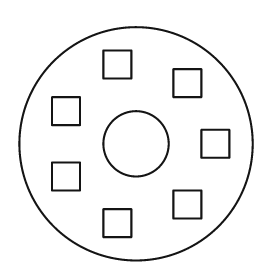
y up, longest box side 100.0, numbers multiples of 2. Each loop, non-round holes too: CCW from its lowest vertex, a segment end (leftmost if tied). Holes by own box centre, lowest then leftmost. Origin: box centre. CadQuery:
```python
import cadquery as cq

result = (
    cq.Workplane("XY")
    .moveTo(0.0, 0.0)
    .circle(50.0)
    .moveTo(-14.0, -40.0)
    .lineTo(-2.0, -40.0)
    .lineTo(-2.0, -28.0)
    .lineTo(-14.0, -28.0)
    .close()
    .moveTo(16.0, -32.0)
    .lineTo(28.0, -32.0)
    .lineTo(28.0, -20.0)
    .lineTo(16.0, -20.0)
    .close()
    .moveTo(-36.0, -20.0)
    .lineTo(-24.0, -20.0)
    .lineTo(-24.0, -8.0)
    .lineTo(-36.0, -8.0)
    .close()
    .moveTo(0.0, 0.0)
    .circle(14.0)
    .moveTo(28.0, -6.0)
    .lineTo(40.0, -6.0)
    .lineTo(40.0, 6.0)
    .lineTo(28.0, 6.0)
    .close()
    .moveTo(-36.0, 8.0)
    .lineTo(-24.0, 8.0)
    .lineTo(-24.0, 20.0)
    .lineTo(-36.0, 20.0)
    .close()
    .moveTo(16.0, 20.0)
    .lineTo(28.0, 20.0)
    .lineTo(28.0, 32.0)
    .lineTo(16.0, 32.0)
    .close()
    .moveTo(-14.0, 28.0)
    .lineTo(-2.0, 28.0)
    .lineTo(-2.0, 40.0)
    .lineTo(-14.0, 40.0)
    .close()
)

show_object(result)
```